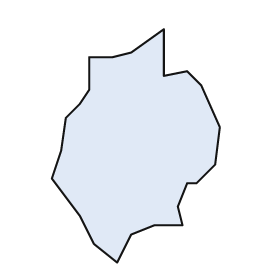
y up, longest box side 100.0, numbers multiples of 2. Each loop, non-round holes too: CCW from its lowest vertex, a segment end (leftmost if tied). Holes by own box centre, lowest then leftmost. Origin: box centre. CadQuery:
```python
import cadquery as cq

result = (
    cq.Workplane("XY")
    .moveTo(-8.0, -50.0)
    .lineTo(-2.0, -38.0)
    .lineTo(8.0, -34.0)
    .lineTo(20.0, -34.0)
    .lineTo(18.0, -26.0)
    .lineTo(22.0, -16.0)
    .lineTo(26.0, -16.0)
    .lineTo(34.0, -8.0)
    .lineTo(36.0, 8.0)
    .lineTo(28.0, 26.0)
    .lineTo(22.0, 32.0)
    .lineTo(12.0, 30.0)
    .lineTo(12.0, 50.0)
    .lineTo(-2.0, 40.0)
    .lineTo(-10.0, 38.0)
    .lineTo(-20.0, 38.0)
    .lineTo(-20.0, 24.0)
    .lineTo(-24.0, 18.0)
    .lineTo(-30.0, 12.0)
    .lineTo(-32.0, -2.0)
    .lineTo(-36.0, -14.0)
    .lineTo(-24.0, -30.0)
    .lineTo(-18.0, -42.0)
    .close()
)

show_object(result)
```